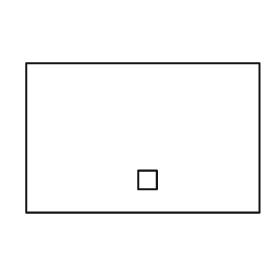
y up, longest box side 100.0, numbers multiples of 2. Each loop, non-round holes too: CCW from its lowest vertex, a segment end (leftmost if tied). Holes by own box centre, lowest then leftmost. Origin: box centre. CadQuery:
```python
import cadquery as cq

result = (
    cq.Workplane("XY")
    .moveTo(-50.0, -32.0)
    .lineTo(50.0, -32.0)
    .lineTo(50.0, 32.0)
    .lineTo(-50.0, 32.0)
    .close()
    .moveTo(-2.0, -22.0)
    .lineTo(6.0, -22.0)
    .lineTo(6.0, -14.0)
    .lineTo(-2.0, -14.0)
    .close()
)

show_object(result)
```